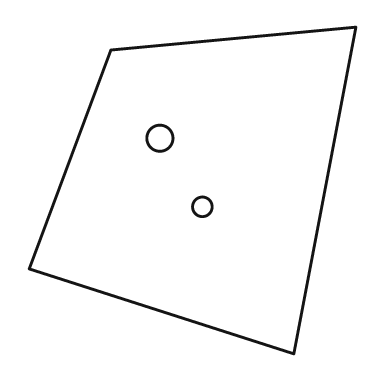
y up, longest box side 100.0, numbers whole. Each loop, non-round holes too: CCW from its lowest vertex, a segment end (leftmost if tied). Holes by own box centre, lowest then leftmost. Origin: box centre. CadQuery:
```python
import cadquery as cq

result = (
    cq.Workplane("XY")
    .moveTo(31.0, -50.0)
    .lineTo(50.0, 50.0)
    .lineTo(-25.0, 43.0)
    .lineTo(-50.0, -24.0)
    .close()
    .moveTo(3.0, -5.0)
    .circle(3.0)
    .moveTo(-10.0, 16.0)
    .circle(4.0)
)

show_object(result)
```